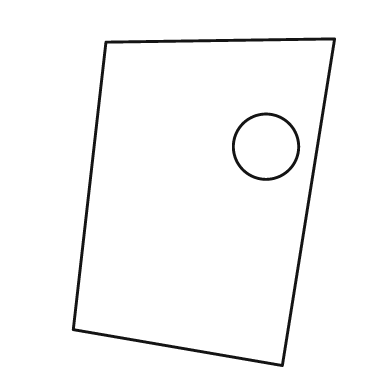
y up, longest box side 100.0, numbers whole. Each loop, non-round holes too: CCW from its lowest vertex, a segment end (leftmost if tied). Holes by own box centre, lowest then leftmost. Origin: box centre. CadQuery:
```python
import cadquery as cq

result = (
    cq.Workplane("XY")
    .moveTo(24.0, -50.0)
    .lineTo(40.0, 50.0)
    .lineTo(-30.0, 49.0)
    .lineTo(-40.0, -39.0)
    .close()
    .moveTo(19.0, 17.0)
    .circle(10.0)
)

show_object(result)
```